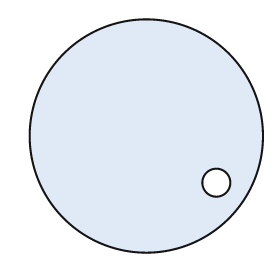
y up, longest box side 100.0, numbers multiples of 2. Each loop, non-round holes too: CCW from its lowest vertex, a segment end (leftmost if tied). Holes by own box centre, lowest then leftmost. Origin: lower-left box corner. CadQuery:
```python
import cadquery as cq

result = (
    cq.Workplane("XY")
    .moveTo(50.0, 50.0)
    .circle(50.0)
    .moveTo(80.0, 30.0)
    .circle(6.0)
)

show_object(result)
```